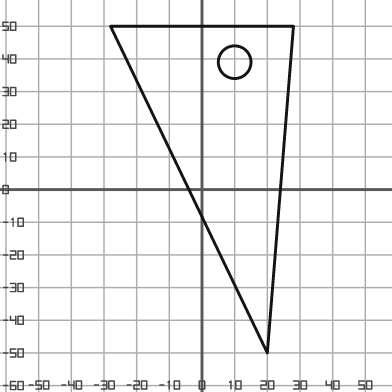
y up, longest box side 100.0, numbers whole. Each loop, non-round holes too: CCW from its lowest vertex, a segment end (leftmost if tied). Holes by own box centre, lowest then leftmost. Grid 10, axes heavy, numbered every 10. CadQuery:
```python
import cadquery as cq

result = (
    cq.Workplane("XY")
    .moveTo(20.0, -50.0)
    .lineTo(28.0, 50.0)
    .lineTo(-28.0, 50.0)
    .close()
    .moveTo(10.0, 39.0)
    .circle(5.0)
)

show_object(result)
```